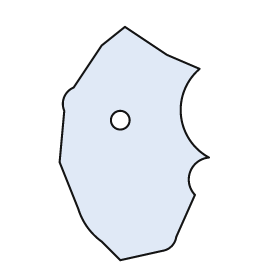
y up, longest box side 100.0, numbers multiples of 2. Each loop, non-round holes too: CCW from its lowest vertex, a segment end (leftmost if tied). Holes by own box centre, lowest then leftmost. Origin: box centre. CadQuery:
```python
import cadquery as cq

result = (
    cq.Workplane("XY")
    .moveTo(-6.0, -50.0)
    .lineTo(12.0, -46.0)
    .threePointArc((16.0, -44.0), (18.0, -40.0))
    .lineTo(26.0, -22.0)
    .threePointArc((24.0, -12.0), (32.0, -6.0))
    .threePointArc((20.0, 12.0), (28.0, 32.0))
    .lineTo(14.0, 38.0)
    .lineTo(-4.0, 50.0)
    .lineTo(-14.0, 42.0)
    .lineTo(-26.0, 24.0)
    .threePointArc((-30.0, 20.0), (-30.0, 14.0))
    .lineTo(-32.0, -8.0)
    .lineTo(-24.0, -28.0)
    .threePointArc((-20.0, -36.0), (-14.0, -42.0))
    .close()
    .moveTo(-6.0, 10.0)
    .circle(4.0)
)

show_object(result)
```